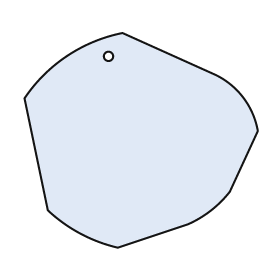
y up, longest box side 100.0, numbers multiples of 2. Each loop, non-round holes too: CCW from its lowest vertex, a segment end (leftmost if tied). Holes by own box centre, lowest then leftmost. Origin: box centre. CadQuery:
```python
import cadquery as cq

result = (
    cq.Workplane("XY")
    .moveTo(-10.0, -46.0)
    .lineTo(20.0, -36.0)
    .threePointArc((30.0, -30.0), (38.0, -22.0))
    .lineTo(50.0, 4.0)
    .threePointArc((44.0, 18.0), (32.0, 28.0))
    .lineTo(-8.0, 46.0)
    .threePointArc((-32.0, 36.0), (-50.0, 18.0))
    .lineTo(-40.0, -30.0)
    .threePointArc((-26.0, -40.0), (-10.0, -46.0))
    .close()
    .moveTo(-14.0, 36.0)
    .circle(2.0)
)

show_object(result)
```